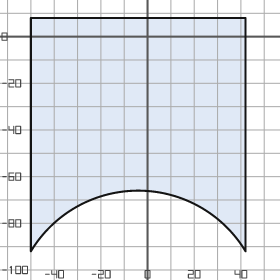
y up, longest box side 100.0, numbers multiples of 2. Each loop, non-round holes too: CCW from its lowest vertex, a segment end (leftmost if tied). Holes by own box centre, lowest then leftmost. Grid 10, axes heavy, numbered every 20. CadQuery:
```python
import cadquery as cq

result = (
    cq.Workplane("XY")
    .moveTo(-50.0, -92.0)
    .threePointArc((-4.0, -66.0), (42.0, -92.0))
    .lineTo(42.0, 8.0)
    .lineTo(-50.0, 8.0)
    .close()
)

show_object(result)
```